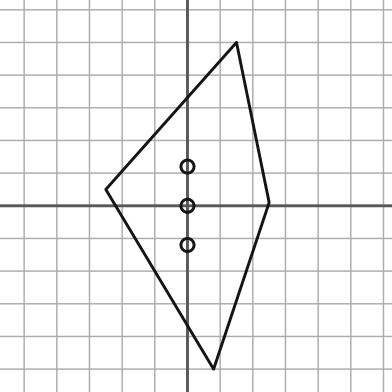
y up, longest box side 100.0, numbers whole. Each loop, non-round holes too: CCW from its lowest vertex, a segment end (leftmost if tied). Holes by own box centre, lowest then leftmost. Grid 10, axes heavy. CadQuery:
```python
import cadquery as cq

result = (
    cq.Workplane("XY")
    .moveTo(8.0, -50.0)
    .lineTo(25.0, 1.0)
    .lineTo(15.0, 50.0)
    .lineTo(-25.0, 5.0)
    .close()
    .moveTo(0.0, -12.0)
    .circle(2.0)
    .moveTo(0.0, 0.0)
    .circle(2.0)
    .moveTo(0.0, 12.0)
    .circle(2.0)
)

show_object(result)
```